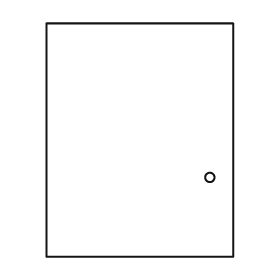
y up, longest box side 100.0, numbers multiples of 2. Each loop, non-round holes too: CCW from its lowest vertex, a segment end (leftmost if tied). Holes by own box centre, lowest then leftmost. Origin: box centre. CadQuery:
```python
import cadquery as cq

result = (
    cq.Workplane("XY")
    .moveTo(-40.0, -50.0)
    .lineTo(40.0, -50.0)
    .lineTo(40.0, 50.0)
    .lineTo(-40.0, 50.0)
    .close()
    .moveTo(30.0, -16.0)
    .circle(2.0)
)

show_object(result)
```